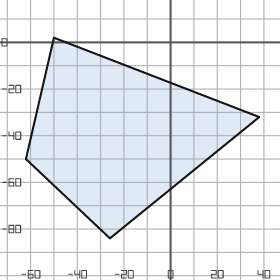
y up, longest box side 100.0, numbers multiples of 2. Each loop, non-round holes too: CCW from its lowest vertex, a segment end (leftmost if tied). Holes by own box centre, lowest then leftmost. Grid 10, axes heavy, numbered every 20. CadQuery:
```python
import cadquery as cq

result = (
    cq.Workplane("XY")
    .moveTo(-26.0, -84.0)
    .lineTo(38.0, -32.0)
    .lineTo(-50.0, 2.0)
    .lineTo(-62.0, -50.0)
    .close()
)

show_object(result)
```